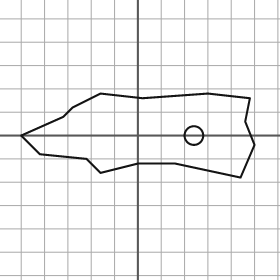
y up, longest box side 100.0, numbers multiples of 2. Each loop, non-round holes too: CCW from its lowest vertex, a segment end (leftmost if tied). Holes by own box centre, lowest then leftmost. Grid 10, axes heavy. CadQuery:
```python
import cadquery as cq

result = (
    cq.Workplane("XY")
    .moveTo(44.0, -18.0)
    .lineTo(50.0, -4.0)
    .lineTo(46.0, 6.0)
    .lineTo(48.0, 16.0)
    .lineTo(30.0, 18.0)
    .lineTo(2.0, 16.0)
    .lineTo(-16.0, 18.0)
    .lineTo(-28.0, 12.0)
    .lineTo(-32.0, 8.0)
    .lineTo(-50.0, 0.0)
    .lineTo(-42.0, -8.0)
    .lineTo(-22.0, -10.0)
    .lineTo(-16.0, -16.0)
    .lineTo(0.0, -12.0)
    .lineTo(16.0, -12.0)
    .close()
    .moveTo(24.0, 0.0)
    .circle(4.0)
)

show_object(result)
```